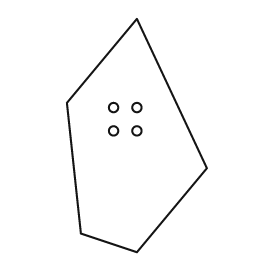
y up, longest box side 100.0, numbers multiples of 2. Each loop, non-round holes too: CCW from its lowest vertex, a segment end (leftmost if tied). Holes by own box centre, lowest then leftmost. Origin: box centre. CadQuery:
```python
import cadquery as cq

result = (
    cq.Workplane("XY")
    .moveTo(0.0, -50.0)
    .lineTo(30.0, -14.0)
    .lineTo(0.0, 50.0)
    .lineTo(-30.0, 14.0)
    .lineTo(-24.0, -42.0)
    .close()
    .moveTo(-10.0, 2.0)
    .circle(2.0)
    .moveTo(0.0, 2.0)
    .circle(2.0)
    .moveTo(-10.0, 12.0)
    .circle(2.0)
    .moveTo(0.0, 12.0)
    .circle(2.0)
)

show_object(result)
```